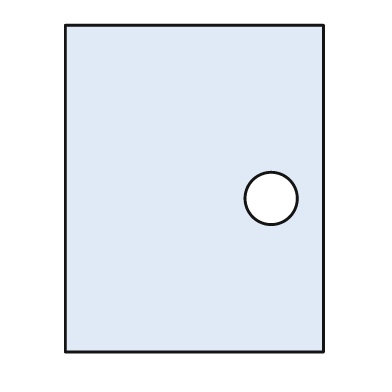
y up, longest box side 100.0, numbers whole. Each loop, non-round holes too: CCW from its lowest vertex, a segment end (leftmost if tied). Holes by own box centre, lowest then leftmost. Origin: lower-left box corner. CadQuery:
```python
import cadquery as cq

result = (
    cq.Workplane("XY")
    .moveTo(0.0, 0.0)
    .lineTo(79.0, 0.0)
    .lineTo(79.0, 100.0)
    .lineTo(0.0, 100.0)
    .close()
    .moveTo(63.0, 47.0)
    .circle(8.0)
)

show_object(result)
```